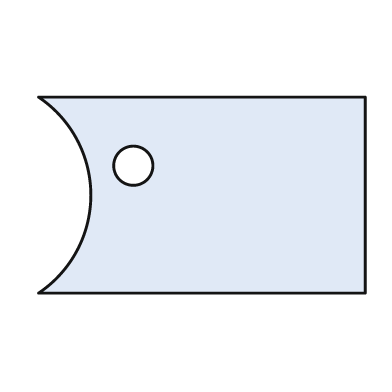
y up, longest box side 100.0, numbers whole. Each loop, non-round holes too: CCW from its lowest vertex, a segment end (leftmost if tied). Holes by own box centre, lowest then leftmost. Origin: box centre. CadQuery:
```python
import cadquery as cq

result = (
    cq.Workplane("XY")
    .moveTo(-50.0, -30.0)
    .lineTo(50.0, -30.0)
    .lineTo(50.0, 30.0)
    .lineTo(-50.0, 30.0)
    .threePointArc((-34.0, 0.0), (-50.0, -30.0))
    .close()
    .moveTo(-21.0, 9.0)
    .circle(6.0)
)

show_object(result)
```